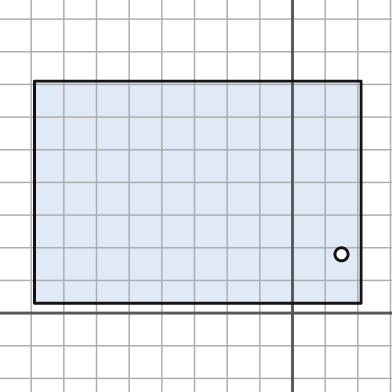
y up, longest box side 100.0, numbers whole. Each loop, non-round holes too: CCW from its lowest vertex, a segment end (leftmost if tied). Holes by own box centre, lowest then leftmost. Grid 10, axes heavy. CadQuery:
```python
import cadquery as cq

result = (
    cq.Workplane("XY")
    .moveTo(-79.0, 3.0)
    .lineTo(21.0, 3.0)
    .lineTo(21.0, 71.0)
    .lineTo(-79.0, 71.0)
    .close()
    .moveTo(15.0, 18.0)
    .circle(2.0)
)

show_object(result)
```